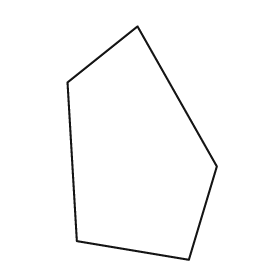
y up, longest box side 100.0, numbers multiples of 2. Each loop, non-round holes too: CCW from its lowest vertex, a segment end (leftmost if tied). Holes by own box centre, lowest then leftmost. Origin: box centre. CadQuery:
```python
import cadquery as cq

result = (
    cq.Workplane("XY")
    .moveTo(20.0, -50.0)
    .lineTo(32.0, -10.0)
    .lineTo(-2.0, 50.0)
    .lineTo(-32.0, 26.0)
    .lineTo(-28.0, -42.0)
    .close()
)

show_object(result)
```